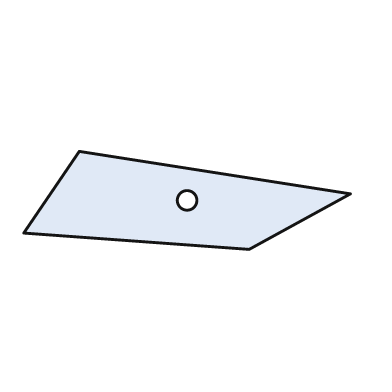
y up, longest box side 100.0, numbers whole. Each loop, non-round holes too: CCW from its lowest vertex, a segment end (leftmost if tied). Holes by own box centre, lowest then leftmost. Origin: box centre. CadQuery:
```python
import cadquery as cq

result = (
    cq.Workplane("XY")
    .moveTo(19.0, -15.0)
    .lineTo(50.0, 2.0)
    .lineTo(-33.0, 15.0)
    .lineTo(-50.0, -10.0)
    .close()
    .moveTo(0.0, 0.0)
    .circle(3.0)
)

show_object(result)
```